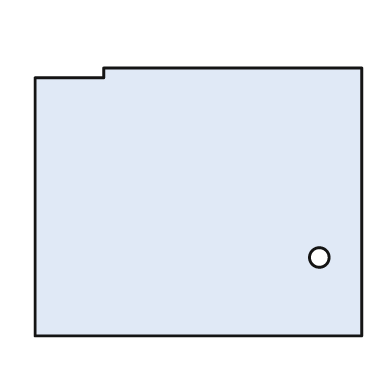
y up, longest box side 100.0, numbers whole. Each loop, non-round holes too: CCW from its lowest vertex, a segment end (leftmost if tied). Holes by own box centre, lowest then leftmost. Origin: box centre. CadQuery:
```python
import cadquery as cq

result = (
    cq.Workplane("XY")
    .moveTo(-50.0, -41.0)
    .lineTo(50.0, -41.0)
    .lineTo(50.0, 41.0)
    .lineTo(-29.0, 41.0)
    .lineTo(-29.0, 38.0)
    .lineTo(-50.0, 38.0)
    .close()
    .moveTo(37.0, -17.0)
    .circle(3.0)
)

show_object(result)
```